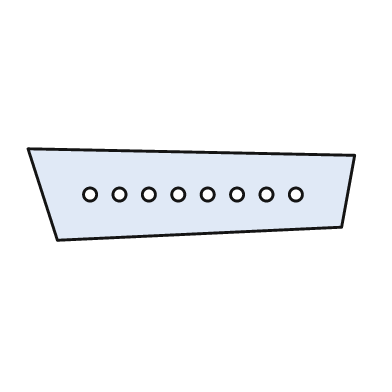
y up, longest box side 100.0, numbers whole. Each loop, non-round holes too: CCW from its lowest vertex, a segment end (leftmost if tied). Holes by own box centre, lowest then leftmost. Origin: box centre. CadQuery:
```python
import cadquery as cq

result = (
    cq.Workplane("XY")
    .moveTo(-41.0, -14.0)
    .lineTo(46.0, -10.0)
    .lineTo(50.0, 12.0)
    .lineTo(-50.0, 14.0)
    .close()
    .moveTo(-31.0, 0.0)
    .circle(2.0)
    .moveTo(-22.0, 0.0)
    .circle(2.0)
    .moveTo(-13.0, 0.0)
    .circle(2.0)
    .moveTo(-4.0, 0.0)
    .circle(2.0)
    .moveTo(5.0, 0.0)
    .circle(2.0)
    .moveTo(14.0, 0.0)
    .circle(2.0)
    .moveTo(23.0, 0.0)
    .circle(2.0)
    .moveTo(32.0, 0.0)
    .circle(2.0)
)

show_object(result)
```